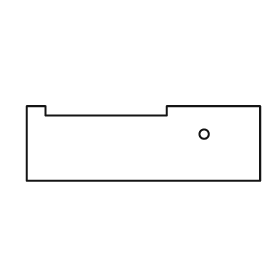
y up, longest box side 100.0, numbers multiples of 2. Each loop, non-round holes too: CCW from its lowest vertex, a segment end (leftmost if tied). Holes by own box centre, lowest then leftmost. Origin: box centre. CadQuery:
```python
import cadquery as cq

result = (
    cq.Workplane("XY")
    .moveTo(-50.0, -16.0)
    .lineTo(50.0, -16.0)
    .lineTo(50.0, 16.0)
    .lineTo(10.0, 16.0)
    .lineTo(10.0, 12.0)
    .lineTo(-42.0, 12.0)
    .lineTo(-42.0, 16.0)
    .lineTo(-50.0, 16.0)
    .close()
    .moveTo(26.0, 4.0)
    .circle(2.0)
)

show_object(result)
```